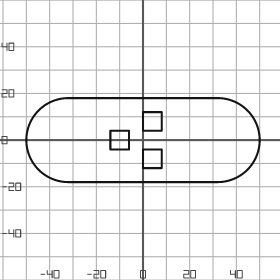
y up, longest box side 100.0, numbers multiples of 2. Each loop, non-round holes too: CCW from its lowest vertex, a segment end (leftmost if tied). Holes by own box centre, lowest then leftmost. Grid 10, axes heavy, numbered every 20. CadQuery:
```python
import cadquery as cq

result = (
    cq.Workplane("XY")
    .moveTo(-32.0, -18.0)
    .lineTo(32.0, -18.0)
    .threePointArc((50.0, 0.0), (32.0, 18.0))
    .lineTo(-32.0, 18.0)
    .threePointArc((-50.0, 0.0), (-32.0, -18.0))
    .close()
    .moveTo(0.0, -12.0)
    .lineTo(8.0, -12.0)
    .lineTo(8.0, -4.0)
    .lineTo(0.0, -4.0)
    .close()
    .moveTo(-14.0, -4.0)
    .lineTo(-6.0, -4.0)
    .lineTo(-6.0, 4.0)
    .lineTo(-14.0, 4.0)
    .close()
    .moveTo(0.0, 4.0)
    .lineTo(8.0, 4.0)
    .lineTo(8.0, 12.0)
    .lineTo(0.0, 12.0)
    .close()
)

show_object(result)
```